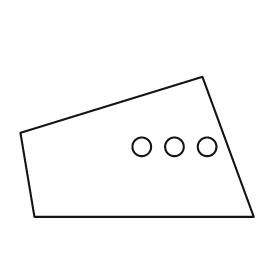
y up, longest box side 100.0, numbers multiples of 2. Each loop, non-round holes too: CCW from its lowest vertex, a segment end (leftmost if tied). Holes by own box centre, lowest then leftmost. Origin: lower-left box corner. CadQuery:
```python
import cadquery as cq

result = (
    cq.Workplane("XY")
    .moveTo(6.0, 0.0)
    .lineTo(100.0, 0.0)
    .lineTo(78.0, 60.0)
    .lineTo(0.0, 36.0)
    .close()
    .moveTo(52.0, 30.0)
    .circle(4.0)
    .moveTo(66.0, 30.0)
    .circle(4.0)
    .moveTo(80.0, 30.0)
    .circle(4.0)
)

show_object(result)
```